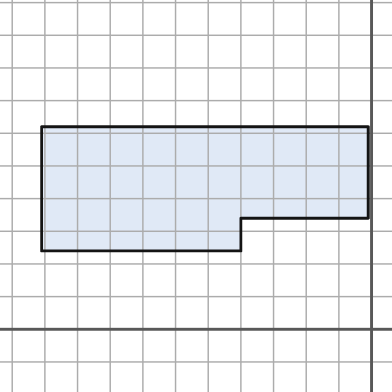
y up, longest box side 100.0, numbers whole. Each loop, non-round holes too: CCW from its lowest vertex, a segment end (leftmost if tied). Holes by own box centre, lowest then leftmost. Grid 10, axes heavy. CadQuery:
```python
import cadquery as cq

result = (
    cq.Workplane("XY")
    .moveTo(-101.0, 24.0)
    .lineTo(-40.0, 24.0)
    .lineTo(-40.0, 34.0)
    .lineTo(-1.0, 34.0)
    .lineTo(-1.0, 62.0)
    .lineTo(-101.0, 62.0)
    .close()
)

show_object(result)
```